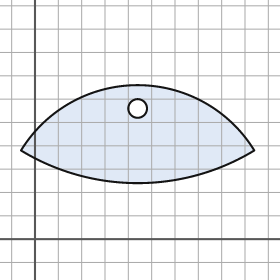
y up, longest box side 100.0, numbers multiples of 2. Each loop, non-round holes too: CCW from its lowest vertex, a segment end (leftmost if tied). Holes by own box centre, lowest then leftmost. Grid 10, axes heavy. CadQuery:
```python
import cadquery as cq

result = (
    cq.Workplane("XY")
    .moveTo(-6.0, 38.0)
    .threePointArc((44.0, 24.0), (94.0, 38.0))
    .threePointArc((44.0, 66.0), (-6.0, 38.0))
    .close()
    .moveTo(44.0, 56.0)
    .circle(4.0)
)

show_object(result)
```